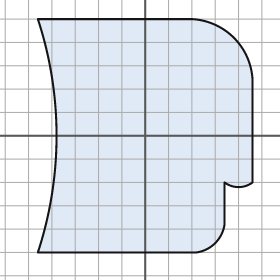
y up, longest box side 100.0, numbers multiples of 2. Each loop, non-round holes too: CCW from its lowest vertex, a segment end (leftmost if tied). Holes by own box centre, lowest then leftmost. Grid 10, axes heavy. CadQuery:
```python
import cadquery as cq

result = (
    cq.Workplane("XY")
    .moveTo(-46.0, -50.0)
    .lineTo(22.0, -50.0)
    .threePointArc((30.0, -46.0), (34.0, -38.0))
    .lineTo(34.0, -20.0)
    .threePointArc((40.0, -22.0), (46.0, -20.0))
    .lineTo(46.0, 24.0)
    .threePointArc((38.0, 42.0), (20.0, 50.0))
    .lineTo(-46.0, 50.0)
    .threePointArc((-38.0, 0.0), (-46.0, -50.0))
    .close()
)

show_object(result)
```